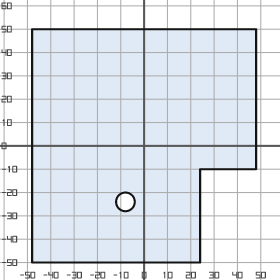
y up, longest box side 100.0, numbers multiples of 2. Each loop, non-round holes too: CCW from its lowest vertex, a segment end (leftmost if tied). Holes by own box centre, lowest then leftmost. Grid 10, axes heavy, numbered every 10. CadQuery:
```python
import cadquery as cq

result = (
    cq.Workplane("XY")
    .moveTo(-48.0, -50.0)
    .lineTo(24.0, -50.0)
    .lineTo(24.0, -10.0)
    .lineTo(48.0, -10.0)
    .lineTo(48.0, 50.0)
    .lineTo(-48.0, 50.0)
    .close()
    .moveTo(-8.0, -24.0)
    .circle(4.0)
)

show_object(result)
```